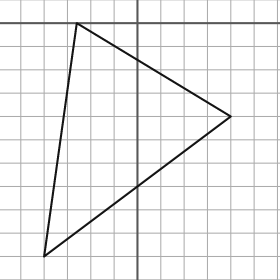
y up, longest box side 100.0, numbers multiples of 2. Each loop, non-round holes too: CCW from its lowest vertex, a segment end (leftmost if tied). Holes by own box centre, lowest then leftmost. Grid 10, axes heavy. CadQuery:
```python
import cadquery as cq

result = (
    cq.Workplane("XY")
    .moveTo(-40.0, -100.0)
    .lineTo(40.0, -40.0)
    .lineTo(-26.0, 0.0)
    .close()
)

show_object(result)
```